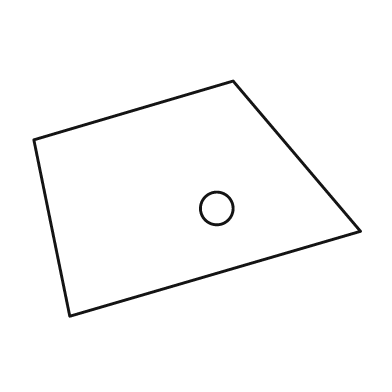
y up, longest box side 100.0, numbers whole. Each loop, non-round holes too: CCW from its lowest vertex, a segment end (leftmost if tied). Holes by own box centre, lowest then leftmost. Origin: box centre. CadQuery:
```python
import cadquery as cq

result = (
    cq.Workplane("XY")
    .moveTo(-39.0, -36.0)
    .lineTo(50.0, -10.0)
    .lineTo(11.0, 36.0)
    .lineTo(-50.0, 18.0)
    .close()
    .moveTo(6.0, -3.0)
    .circle(5.0)
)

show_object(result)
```